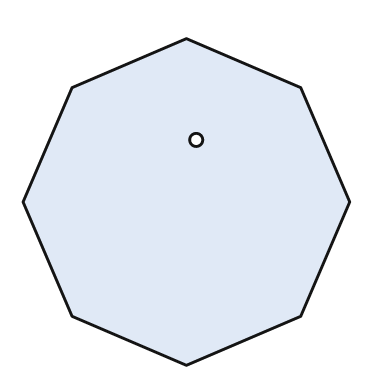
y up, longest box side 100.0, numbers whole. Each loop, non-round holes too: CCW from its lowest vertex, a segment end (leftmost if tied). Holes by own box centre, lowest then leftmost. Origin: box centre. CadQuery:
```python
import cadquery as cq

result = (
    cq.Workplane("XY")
    .moveTo(0.0, -50.0)
    .lineTo(35.0, -35.0)
    .lineTo(50.0, 0.0)
    .lineTo(35.0, 35.0)
    .lineTo(0.0, 50.0)
    .lineTo(-35.0, 35.0)
    .lineTo(-50.0, 0.0)
    .lineTo(-35.0, -35.0)
    .close()
    .moveTo(3.0, 19.0)
    .circle(2.0)
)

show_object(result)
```